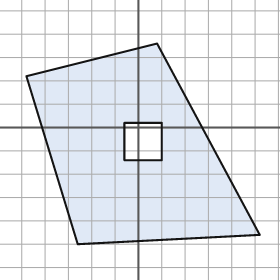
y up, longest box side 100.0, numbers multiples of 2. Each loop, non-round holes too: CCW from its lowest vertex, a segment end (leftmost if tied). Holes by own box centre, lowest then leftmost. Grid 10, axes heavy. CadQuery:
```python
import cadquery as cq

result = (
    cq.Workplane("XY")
    .moveTo(-26.0, -50.0)
    .lineTo(52.0, -46.0)
    .lineTo(8.0, 36.0)
    .lineTo(-48.0, 22.0)
    .close()
    .moveTo(-6.0, -14.0)
    .lineTo(10.0, -14.0)
    .lineTo(10.0, 2.0)
    .lineTo(-6.0, 2.0)
    .close()
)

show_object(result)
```